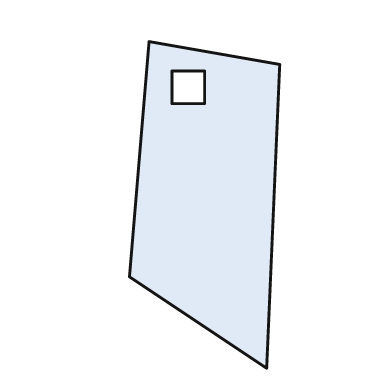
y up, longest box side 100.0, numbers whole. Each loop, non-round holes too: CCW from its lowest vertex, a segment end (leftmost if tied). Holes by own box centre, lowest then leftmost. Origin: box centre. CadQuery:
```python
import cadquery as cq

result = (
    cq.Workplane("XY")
    .moveTo(19.0, -50.0)
    .lineTo(23.0, 43.0)
    .lineTo(-17.0, 50.0)
    .lineTo(-23.0, -22.0)
    .close()
    .moveTo(-10.0, 31.0)
    .lineTo(0.0, 31.0)
    .lineTo(0.0, 41.0)
    .lineTo(-10.0, 41.0)
    .close()
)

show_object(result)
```